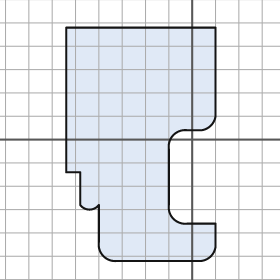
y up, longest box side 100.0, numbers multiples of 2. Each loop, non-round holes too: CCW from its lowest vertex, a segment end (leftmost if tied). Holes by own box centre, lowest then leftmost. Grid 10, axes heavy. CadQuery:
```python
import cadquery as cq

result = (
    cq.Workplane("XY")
    .moveTo(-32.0, -52.0)
    .lineTo(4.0, -52.0)
    .threePointArc((8.0, -50.0), (10.0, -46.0))
    .lineTo(10.0, -36.0)
    .lineTo(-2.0, -36.0)
    .threePointArc((-8.0, -34.0), (-10.0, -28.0))
    .lineTo(-10.0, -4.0)
    .threePointArc((-8.0, 2.0), (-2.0, 4.0))
    .lineTo(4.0, 4.0)
    .threePointArc((8.0, 6.0), (10.0, 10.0))
    .lineTo(10.0, 48.0)
    .lineTo(-54.0, 48.0)
    .lineTo(-54.0, -14.0)
    .lineTo(-48.0, -14.0)
    .lineTo(-48.0, -28.0)
    .threePointArc((-44.0, -30.0), (-40.0, -28.0))
    .lineTo(-40.0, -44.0)
    .threePointArc((-38.0, -50.0), (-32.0, -52.0))
    .close()
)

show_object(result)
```